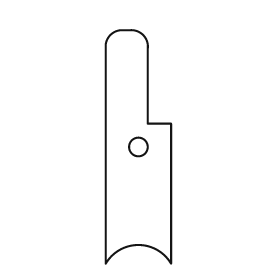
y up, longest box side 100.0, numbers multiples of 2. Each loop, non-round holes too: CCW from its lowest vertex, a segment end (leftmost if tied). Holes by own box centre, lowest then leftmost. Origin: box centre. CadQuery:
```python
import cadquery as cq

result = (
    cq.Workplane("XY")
    .moveTo(-14.0, -50.0)
    .threePointArc((0.0, -42.0), (14.0, -50.0))
    .lineTo(14.0, 10.0)
    .lineTo(4.0, 10.0)
    .lineTo(4.0, 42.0)
    .threePointArc((2.0, 48.0), (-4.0, 50.0))
    .lineTo(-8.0, 50.0)
    .threePointArc((-12.0, 48.0), (-14.0, 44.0))
    .close()
    .moveTo(0.0, 0.0)
    .circle(4.0)
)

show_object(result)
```